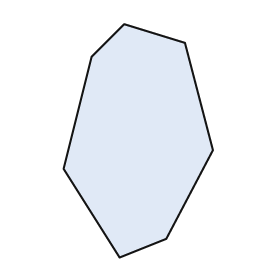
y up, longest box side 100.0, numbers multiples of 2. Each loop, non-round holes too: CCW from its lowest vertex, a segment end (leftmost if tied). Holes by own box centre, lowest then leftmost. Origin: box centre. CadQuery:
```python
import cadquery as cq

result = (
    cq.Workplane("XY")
    .moveTo(-8.0, -50.0)
    .lineTo(12.0, -42.0)
    .lineTo(32.0, -4.0)
    .lineTo(20.0, 42.0)
    .lineTo(-6.0, 50.0)
    .lineTo(-20.0, 36.0)
    .lineTo(-32.0, -12.0)
    .close()
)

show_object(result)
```